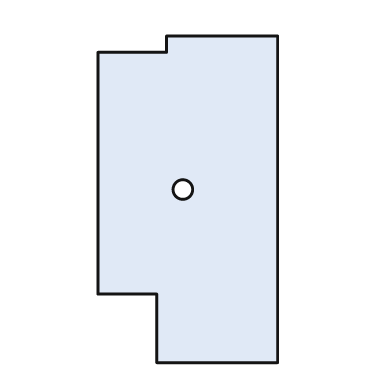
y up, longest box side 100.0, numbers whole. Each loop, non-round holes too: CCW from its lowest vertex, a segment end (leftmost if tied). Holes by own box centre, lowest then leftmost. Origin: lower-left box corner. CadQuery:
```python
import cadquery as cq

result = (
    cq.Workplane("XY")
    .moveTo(18.0, 0.0)
    .lineTo(55.0, 0.0)
    .lineTo(55.0, 100.0)
    .lineTo(21.0, 100.0)
    .lineTo(21.0, 95.0)
    .lineTo(0.0, 95.0)
    .lineTo(0.0, 21.0)
    .lineTo(18.0, 21.0)
    .close()
    .moveTo(26.0, 53.0)
    .circle(3.0)
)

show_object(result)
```